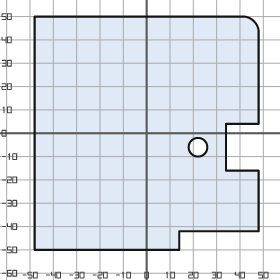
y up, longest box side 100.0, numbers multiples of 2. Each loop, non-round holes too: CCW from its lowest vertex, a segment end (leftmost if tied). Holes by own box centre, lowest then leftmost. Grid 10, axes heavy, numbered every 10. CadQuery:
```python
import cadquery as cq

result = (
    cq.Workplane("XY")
    .moveTo(-48.0, -50.0)
    .lineTo(14.0, -50.0)
    .lineTo(14.0, -42.0)
    .lineTo(48.0, -42.0)
    .lineTo(48.0, -16.0)
    .lineTo(34.0, -16.0)
    .lineTo(34.0, 4.0)
    .lineTo(48.0, 4.0)
    .lineTo(48.0, 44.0)
    .threePointArc((46.0, 48.0), (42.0, 50.0))
    .lineTo(-48.0, 50.0)
    .close()
    .moveTo(22.0, -6.0)
    .circle(4.0)
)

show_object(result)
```